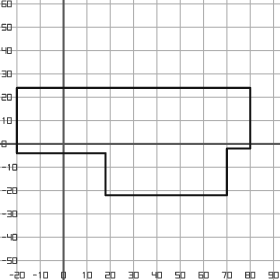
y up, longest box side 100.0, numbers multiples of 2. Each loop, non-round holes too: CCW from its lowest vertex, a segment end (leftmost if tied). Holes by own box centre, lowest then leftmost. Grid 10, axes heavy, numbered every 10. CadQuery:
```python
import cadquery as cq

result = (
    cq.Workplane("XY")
    .moveTo(18.0, -22.0)
    .lineTo(70.0, -22.0)
    .lineTo(70.0, -2.0)
    .lineTo(80.0, -2.0)
    .lineTo(80.0, 24.0)
    .lineTo(-20.0, 24.0)
    .lineTo(-20.0, -4.0)
    .lineTo(18.0, -4.0)
    .close()
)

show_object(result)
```